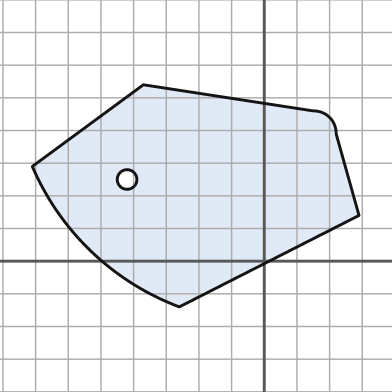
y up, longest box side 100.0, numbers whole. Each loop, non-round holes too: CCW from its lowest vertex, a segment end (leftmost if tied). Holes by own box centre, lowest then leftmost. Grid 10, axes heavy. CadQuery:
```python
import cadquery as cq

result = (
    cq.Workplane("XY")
    .moveTo(-26.0, -14.0)
    .lineTo(29.0, 14.0)
    .lineTo(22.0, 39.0)
    .threePointArc((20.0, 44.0), (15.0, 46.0))
    .lineTo(-37.0, 54.0)
    .lineTo(-71.0, 29.0)
    .threePointArc((-53.0, 3.0), (-26.0, -14.0))
    .close()
    .moveTo(-42.0, 25.0)
    .circle(3.0)
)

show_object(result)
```